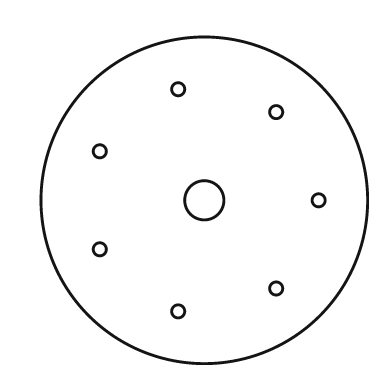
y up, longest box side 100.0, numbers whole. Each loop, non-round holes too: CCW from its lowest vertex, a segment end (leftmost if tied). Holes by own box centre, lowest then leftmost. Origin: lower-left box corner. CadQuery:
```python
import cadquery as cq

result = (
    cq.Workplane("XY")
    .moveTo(50.0, 50.0)
    .circle(50.0)
    .moveTo(42.0, 16.0)
    .circle(2.0)
    .moveTo(72.0, 23.0)
    .circle(2.0)
    .moveTo(18.0, 35.0)
    .circle(2.0)
    .moveTo(50.0, 50.0)
    .circle(6.0)
    .moveTo(85.0, 50.0)
    .circle(2.0)
    .moveTo(18.0, 65.0)
    .circle(2.0)
    .moveTo(72.0, 77.0)
    .circle(2.0)
    .moveTo(42.0, 84.0)
    .circle(2.0)
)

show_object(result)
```